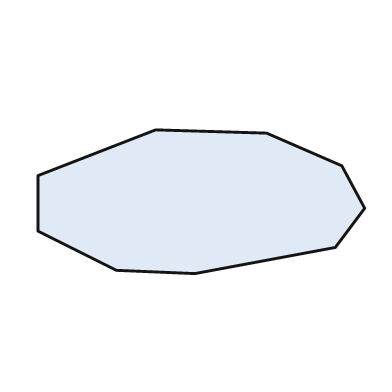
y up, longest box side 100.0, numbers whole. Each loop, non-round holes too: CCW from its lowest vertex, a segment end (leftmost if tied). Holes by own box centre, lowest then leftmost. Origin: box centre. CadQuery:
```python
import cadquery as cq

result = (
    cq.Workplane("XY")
    .moveTo(-2.0, -22.0)
    .lineTo(41.0, -14.0)
    .lineTo(50.0, -2.0)
    .lineTo(43.0, 11.0)
    .lineTo(20.0, 21.0)
    .lineTo(-14.0, 22.0)
    .lineTo(-50.0, 8.0)
    .lineTo(-50.0, -9.0)
    .lineTo(-26.0, -21.0)
    .close()
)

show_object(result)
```